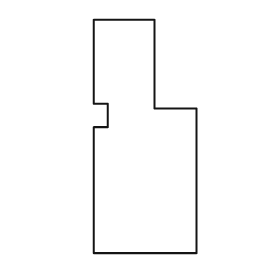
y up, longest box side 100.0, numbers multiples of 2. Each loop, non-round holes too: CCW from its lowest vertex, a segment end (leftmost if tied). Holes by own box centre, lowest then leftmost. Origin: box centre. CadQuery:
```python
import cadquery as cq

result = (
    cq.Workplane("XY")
    .moveTo(-22.0, -50.0)
    .lineTo(22.0, -50.0)
    .lineTo(22.0, 12.0)
    .lineTo(4.0, 12.0)
    .lineTo(4.0, 50.0)
    .lineTo(-22.0, 50.0)
    .lineTo(-22.0, 14.0)
    .lineTo(-16.0, 14.0)
    .lineTo(-16.0, 4.0)
    .lineTo(-22.0, 4.0)
    .close()
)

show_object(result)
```